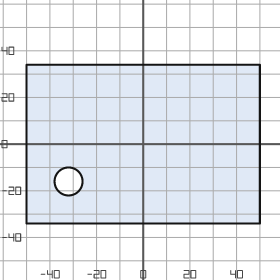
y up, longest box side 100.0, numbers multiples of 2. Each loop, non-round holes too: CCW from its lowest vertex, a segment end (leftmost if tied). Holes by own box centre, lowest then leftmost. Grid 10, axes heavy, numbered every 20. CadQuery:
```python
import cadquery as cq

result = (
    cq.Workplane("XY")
    .moveTo(-50.0, -34.0)
    .lineTo(50.0, -34.0)
    .lineTo(50.0, 34.0)
    .lineTo(-50.0, 34.0)
    .close()
    .moveTo(-32.0, -16.0)
    .circle(6.0)
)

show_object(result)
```